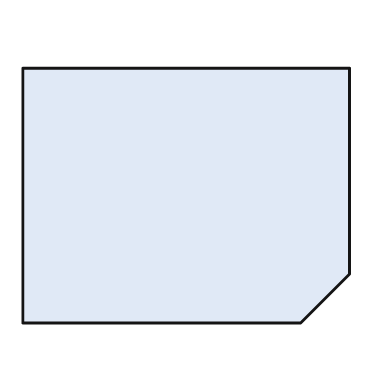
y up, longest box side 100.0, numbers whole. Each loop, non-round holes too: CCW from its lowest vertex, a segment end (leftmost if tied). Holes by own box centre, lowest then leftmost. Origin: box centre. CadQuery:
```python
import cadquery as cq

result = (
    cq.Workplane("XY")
    .moveTo(-50.0, -39.0)
    .lineTo(35.0, -39.0)
    .lineTo(50.0, -24.0)
    .lineTo(50.0, 39.0)
    .lineTo(-50.0, 39.0)
    .close()
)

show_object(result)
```